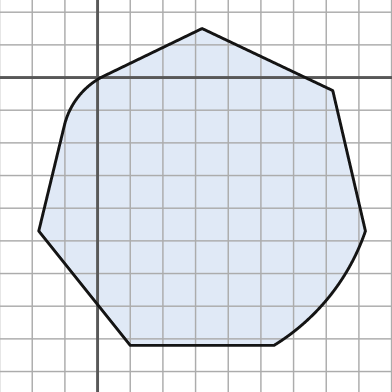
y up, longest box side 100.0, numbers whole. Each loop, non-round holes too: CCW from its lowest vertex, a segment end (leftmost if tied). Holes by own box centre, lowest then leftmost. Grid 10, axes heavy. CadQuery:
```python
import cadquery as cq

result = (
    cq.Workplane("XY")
    .moveTo(10.0, -82.0)
    .lineTo(54.0, -82.0)
    .threePointArc((71.0, -67.0), (82.0, -47.0))
    .lineTo(72.0, -4.0)
    .lineTo(32.0, 15.0)
    .lineTo(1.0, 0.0)
    .threePointArc((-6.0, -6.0), (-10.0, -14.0))
    .lineTo(-18.0, -47.0)
    .close()
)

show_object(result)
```